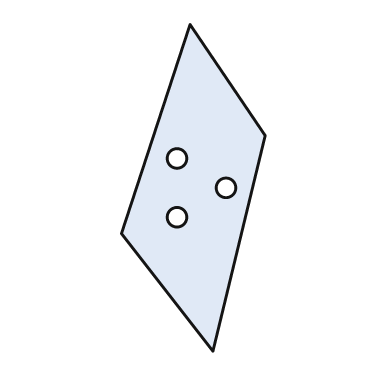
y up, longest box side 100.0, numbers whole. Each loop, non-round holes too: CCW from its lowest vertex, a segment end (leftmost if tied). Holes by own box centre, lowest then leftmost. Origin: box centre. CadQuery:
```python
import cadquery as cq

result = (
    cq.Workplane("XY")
    .moveTo(6.0, -50.0)
    .lineTo(22.0, 16.0)
    .lineTo(-1.0, 50.0)
    .lineTo(-22.0, -14.0)
    .close()
    .moveTo(-5.0, -9.0)
    .circle(3.0)
    .moveTo(10.0, 0.0)
    .circle(3.0)
    .moveTo(-5.0, 9.0)
    .circle(3.0)
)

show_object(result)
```